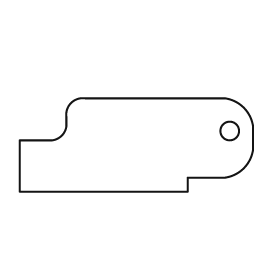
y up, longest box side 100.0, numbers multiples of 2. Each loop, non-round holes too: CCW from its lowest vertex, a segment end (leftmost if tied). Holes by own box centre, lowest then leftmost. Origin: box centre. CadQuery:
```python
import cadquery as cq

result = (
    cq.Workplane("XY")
    .moveTo(-50.0, -20.0)
    .lineTo(22.0, -20.0)
    .lineTo(22.0, -14.0)
    .lineTo(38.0, -14.0)
    .threePointArc((46.0, -10.0), (50.0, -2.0))
    .lineTo(50.0, 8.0)
    .threePointArc((46.0, 16.0), (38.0, 20.0))
    .lineTo(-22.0, 20.0)
    .threePointArc((-28.0, 18.0), (-30.0, 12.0))
    .lineTo(-30.0, 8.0)
    .threePointArc((-32.0, 4.0), (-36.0, 2.0))
    .lineTo(-50.0, 2.0)
    .close()
    .moveTo(40.0, 6.0)
    .circle(4.0)
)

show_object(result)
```